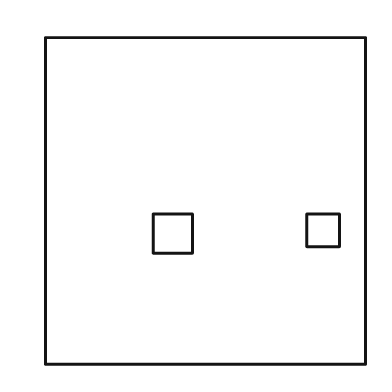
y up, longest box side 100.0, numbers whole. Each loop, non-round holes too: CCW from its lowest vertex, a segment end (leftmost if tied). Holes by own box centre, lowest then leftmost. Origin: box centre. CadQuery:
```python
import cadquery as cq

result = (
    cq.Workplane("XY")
    .moveTo(-49.0, -50.0)
    .lineTo(49.0, -50.0)
    .lineTo(49.0, 50.0)
    .lineTo(-49.0, 50.0)
    .close()
    .moveTo(-16.0, -16.0)
    .lineTo(-4.0, -16.0)
    .lineTo(-4.0, -4.0)
    .lineTo(-16.0, -4.0)
    .close()
    .moveTo(31.0, -14.0)
    .lineTo(41.0, -14.0)
    .lineTo(41.0, -4.0)
    .lineTo(31.0, -4.0)
    .close()
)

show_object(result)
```